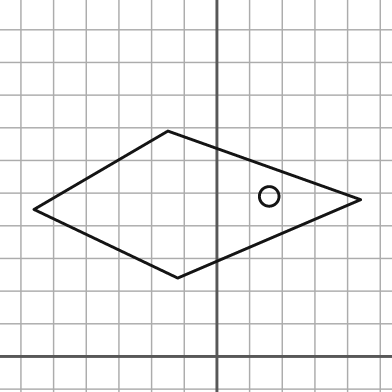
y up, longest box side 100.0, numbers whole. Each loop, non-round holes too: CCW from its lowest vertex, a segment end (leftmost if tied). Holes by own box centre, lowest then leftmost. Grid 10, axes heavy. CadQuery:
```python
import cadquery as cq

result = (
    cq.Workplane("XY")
    .moveTo(-12.0, 24.0)
    .lineTo(44.0, 48.0)
    .lineTo(-15.0, 69.0)
    .lineTo(-56.0, 45.0)
    .close()
    .moveTo(16.0, 49.0)
    .circle(3.0)
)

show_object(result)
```